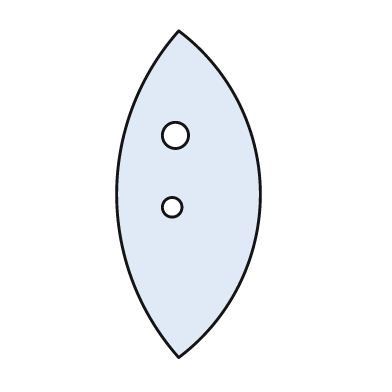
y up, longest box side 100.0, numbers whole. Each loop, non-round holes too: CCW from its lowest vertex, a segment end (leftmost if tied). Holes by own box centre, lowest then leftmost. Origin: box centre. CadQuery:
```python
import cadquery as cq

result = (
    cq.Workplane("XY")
    .moveTo(-3.0, -50.0)
    .threePointArc((22.0, 0.0), (-3.0, 50.0))
    .threePointArc((-22.0, 0.0), (-3.0, -50.0))
    .close()
    .moveTo(-5.0, -4.0)
    .circle(3.0)
    .moveTo(-4.0, 18.0)
    .circle(4.0)
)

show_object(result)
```